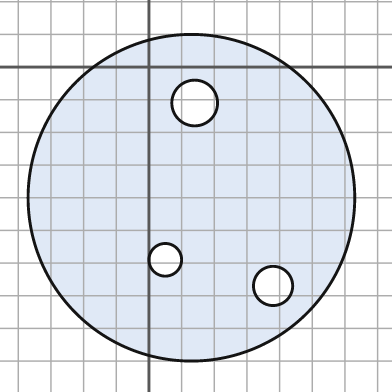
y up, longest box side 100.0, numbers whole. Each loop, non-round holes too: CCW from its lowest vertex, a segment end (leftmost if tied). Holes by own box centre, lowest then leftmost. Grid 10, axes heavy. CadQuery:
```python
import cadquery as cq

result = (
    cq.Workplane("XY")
    .moveTo(13.0, -40.0)
    .circle(50.0)
    .moveTo(38.0, -67.0)
    .circle(6.0)
    .moveTo(5.0, -59.0)
    .circle(5.0)
    .moveTo(14.0, -11.0)
    .circle(7.0)
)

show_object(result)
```